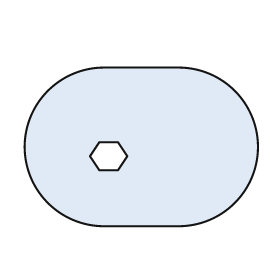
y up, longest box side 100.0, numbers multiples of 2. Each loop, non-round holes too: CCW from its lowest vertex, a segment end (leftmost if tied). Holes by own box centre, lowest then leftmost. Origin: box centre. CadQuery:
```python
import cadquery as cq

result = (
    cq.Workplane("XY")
    .moveTo(-16.0, -34.0)
    .lineTo(16.0, -34.0)
    .threePointArc((50.0, 0.0), (16.0, 34.0))
    .lineTo(-16.0, 34.0)
    .threePointArc((-50.0, 0.0), (-16.0, -34.0))
    .close()
    .moveTo(-18.0, -10.0)
    .lineTo(-10.0, -10.0)
    .lineTo(-6.0, -4.0)
    .lineTo(-10.0, 2.0)
    .lineTo(-18.0, 2.0)
    .lineTo(-22.0, -4.0)
    .close()
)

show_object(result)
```